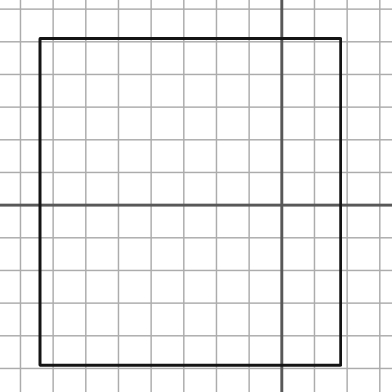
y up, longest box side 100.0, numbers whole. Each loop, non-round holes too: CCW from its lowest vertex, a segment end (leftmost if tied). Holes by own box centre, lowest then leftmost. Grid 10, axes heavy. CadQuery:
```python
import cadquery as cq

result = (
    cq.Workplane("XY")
    .moveTo(-74.0, -49.0)
    .lineTo(18.0, -49.0)
    .lineTo(18.0, 51.0)
    .lineTo(-74.0, 51.0)
    .close()
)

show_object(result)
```